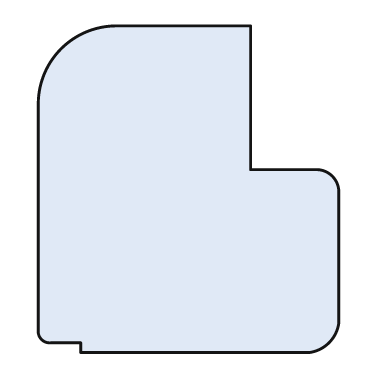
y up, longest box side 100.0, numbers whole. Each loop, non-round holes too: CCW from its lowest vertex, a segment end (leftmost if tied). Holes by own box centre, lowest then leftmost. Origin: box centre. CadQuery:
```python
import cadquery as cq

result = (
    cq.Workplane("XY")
    .moveTo(-33.0, -50.0)
    .lineTo(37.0, -50.0)
    .threePointArc((43.0, -47.0), (46.0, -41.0))
    .lineTo(46.0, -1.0)
    .threePointArc((44.0, 4.0), (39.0, 6.0))
    .lineTo(19.0, 6.0)
    .lineTo(19.0, 50.0)
    .lineTo(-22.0, 50.0)
    .threePointArc((-39.0, 43.0), (-46.0, 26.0))
    .lineTo(-46.0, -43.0)
    .threePointArc((-45.0, -46.0), (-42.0, -47.0))
    .lineTo(-33.0, -47.0)
    .close()
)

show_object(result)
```